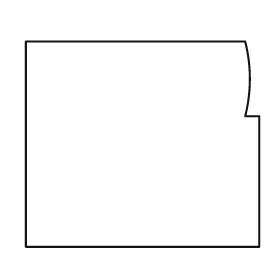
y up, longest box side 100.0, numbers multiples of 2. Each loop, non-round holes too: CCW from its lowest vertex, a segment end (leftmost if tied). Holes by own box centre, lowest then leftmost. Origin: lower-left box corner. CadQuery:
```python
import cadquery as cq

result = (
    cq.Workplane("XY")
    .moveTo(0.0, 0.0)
    .lineTo(100.0, 0.0)
    .lineTo(100.0, 56.0)
    .lineTo(94.0, 56.0)
    .threePointArc((96.0, 72.0), (94.0, 88.0))
    .lineTo(0.0, 88.0)
    .close()
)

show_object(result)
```